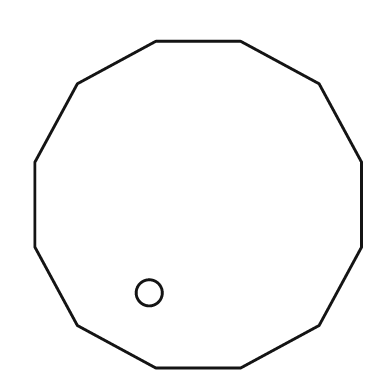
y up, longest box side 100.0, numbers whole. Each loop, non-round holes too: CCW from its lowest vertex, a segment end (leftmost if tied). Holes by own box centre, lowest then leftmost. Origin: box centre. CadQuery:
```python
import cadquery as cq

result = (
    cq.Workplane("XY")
    .moveTo(-13.0, -50.0)
    .lineTo(13.0, -50.0)
    .lineTo(37.0, -37.0)
    .lineTo(50.0, -13.0)
    .lineTo(50.0, 13.0)
    .lineTo(37.0, 37.0)
    .lineTo(13.0, 50.0)
    .lineTo(-13.0, 50.0)
    .lineTo(-37.0, 37.0)
    .lineTo(-50.0, 13.0)
    .lineTo(-50.0, -13.0)
    .lineTo(-37.0, -37.0)
    .close()
    .moveTo(-15.0, -27.0)
    .circle(4.0)
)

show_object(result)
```